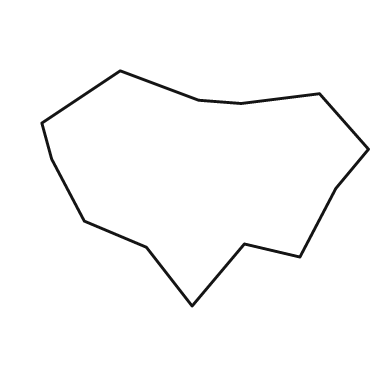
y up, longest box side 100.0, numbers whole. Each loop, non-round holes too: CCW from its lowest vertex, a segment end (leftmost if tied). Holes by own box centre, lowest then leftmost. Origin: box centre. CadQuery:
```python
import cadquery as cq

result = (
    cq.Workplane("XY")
    .moveTo(-4.0, -36.0)
    .lineTo(12.0, -17.0)
    .lineTo(29.0, -21.0)
    .lineTo(40.0, 0.0)
    .lineTo(50.0, 12.0)
    .lineTo(35.0, 29.0)
    .lineTo(11.0, 26.0)
    .lineTo(-2.0, 27.0)
    .lineTo(-26.0, 36.0)
    .lineTo(-50.0, 20.0)
    .lineTo(-47.0, 9.0)
    .lineTo(-37.0, -10.0)
    .lineTo(-18.0, -18.0)
    .close()
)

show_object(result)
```